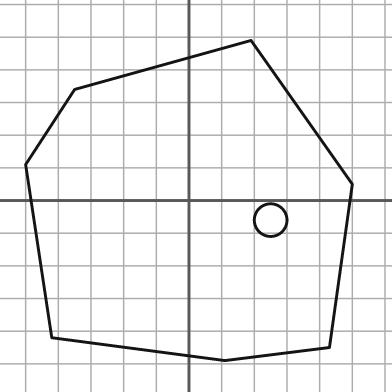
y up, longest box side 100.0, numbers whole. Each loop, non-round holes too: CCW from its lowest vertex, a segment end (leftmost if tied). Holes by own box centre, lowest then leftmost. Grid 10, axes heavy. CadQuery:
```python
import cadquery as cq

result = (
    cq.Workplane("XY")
    .moveTo(11.0, -49.0)
    .lineTo(43.0, -45.0)
    .lineTo(50.0, 5.0)
    .lineTo(19.0, 49.0)
    .lineTo(-35.0, 34.0)
    .lineTo(-50.0, 11.0)
    .lineTo(-42.0, -42.0)
    .close()
    .moveTo(25.0, -6.0)
    .circle(5.0)
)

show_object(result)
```